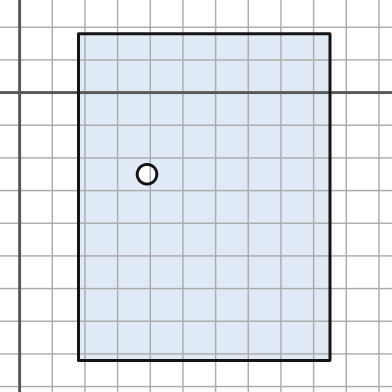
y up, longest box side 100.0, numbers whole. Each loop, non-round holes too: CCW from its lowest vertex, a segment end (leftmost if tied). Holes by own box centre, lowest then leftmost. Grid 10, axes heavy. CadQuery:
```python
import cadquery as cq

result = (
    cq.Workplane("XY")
    .moveTo(18.0, -82.0)
    .lineTo(95.0, -82.0)
    .lineTo(95.0, 18.0)
    .lineTo(18.0, 18.0)
    .close()
    .moveTo(39.0, -25.0)
    .circle(3.0)
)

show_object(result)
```